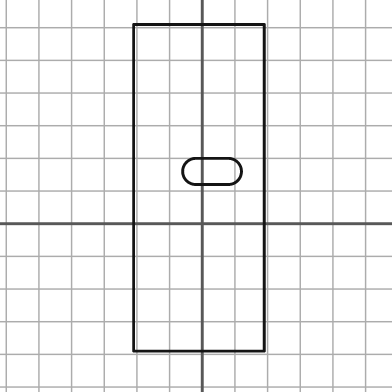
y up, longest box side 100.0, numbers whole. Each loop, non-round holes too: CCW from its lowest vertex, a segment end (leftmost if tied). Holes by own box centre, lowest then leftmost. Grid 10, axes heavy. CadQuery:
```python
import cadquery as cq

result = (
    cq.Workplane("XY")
    .moveTo(-21.0, -39.0)
    .lineTo(19.0, -39.0)
    .lineTo(19.0, 61.0)
    .lineTo(-21.0, 61.0)
    .close()
    .moveTo(-2.0, 12.0)
    .lineTo(8.0, 12.0)
    .threePointArc((12.0, 16.0), (8.0, 20.0))
    .lineTo(-2.0, 20.0)
    .threePointArc((-6.0, 16.0), (-2.0, 12.0))
    .close()
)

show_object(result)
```